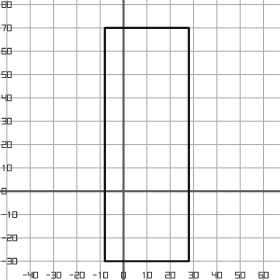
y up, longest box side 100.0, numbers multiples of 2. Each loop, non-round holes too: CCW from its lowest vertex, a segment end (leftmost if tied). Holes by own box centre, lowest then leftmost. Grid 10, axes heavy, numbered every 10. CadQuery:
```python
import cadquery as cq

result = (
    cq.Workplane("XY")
    .moveTo(-8.0, -30.0)
    .lineTo(28.0, -30.0)
    .lineTo(28.0, 70.0)
    .lineTo(-8.0, 70.0)
    .close()
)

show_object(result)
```